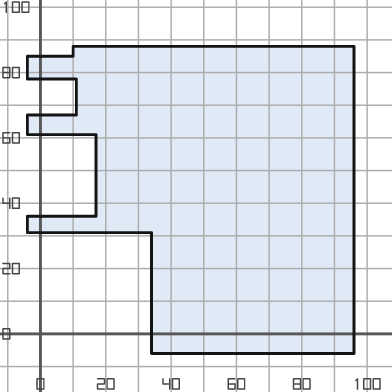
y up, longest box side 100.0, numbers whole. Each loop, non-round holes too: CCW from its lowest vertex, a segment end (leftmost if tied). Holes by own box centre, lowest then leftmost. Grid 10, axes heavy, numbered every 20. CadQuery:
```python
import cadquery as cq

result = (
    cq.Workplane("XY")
    .moveTo(34.0, -6.0)
    .lineTo(96.0, -6.0)
    .lineTo(96.0, 88.0)
    .lineTo(10.0, 88.0)
    .lineTo(10.0, 85.0)
    .lineTo(-4.0, 85.0)
    .lineTo(-4.0, 78.0)
    .lineTo(11.0, 78.0)
    .lineTo(11.0, 67.0)
    .lineTo(-4.0, 67.0)
    .lineTo(-4.0, 61.0)
    .lineTo(17.0, 61.0)
    .lineTo(17.0, 36.0)
    .lineTo(-4.0, 36.0)
    .lineTo(-4.0, 31.0)
    .lineTo(34.0, 31.0)
    .close()
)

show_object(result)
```